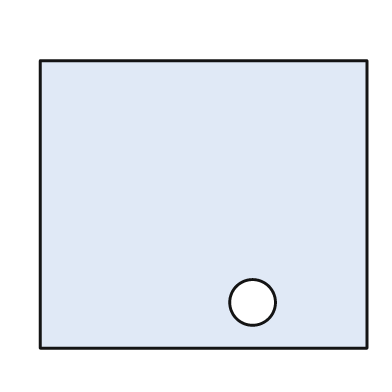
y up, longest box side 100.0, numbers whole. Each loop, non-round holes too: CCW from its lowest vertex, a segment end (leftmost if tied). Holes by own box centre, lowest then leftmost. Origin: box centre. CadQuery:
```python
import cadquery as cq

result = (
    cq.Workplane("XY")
    .moveTo(-50.0, -44.0)
    .lineTo(50.0, -44.0)
    .lineTo(50.0, 44.0)
    .lineTo(-50.0, 44.0)
    .close()
    .moveTo(15.0, -30.0)
    .circle(7.0)
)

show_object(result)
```